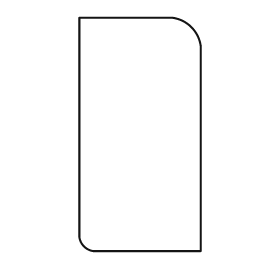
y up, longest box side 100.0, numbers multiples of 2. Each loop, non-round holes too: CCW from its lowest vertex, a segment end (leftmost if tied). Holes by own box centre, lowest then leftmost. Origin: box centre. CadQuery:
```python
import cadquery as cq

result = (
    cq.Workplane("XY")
    .moveTo(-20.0, -50.0)
    .lineTo(26.0, -50.0)
    .lineTo(26.0, 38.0)
    .threePointArc((22.0, 46.0), (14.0, 50.0))
    .lineTo(-26.0, 50.0)
    .lineTo(-26.0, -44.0)
    .threePointArc((-24.0, -48.0), (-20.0, -50.0))
    .close()
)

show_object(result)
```